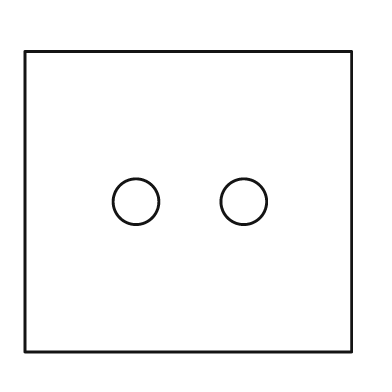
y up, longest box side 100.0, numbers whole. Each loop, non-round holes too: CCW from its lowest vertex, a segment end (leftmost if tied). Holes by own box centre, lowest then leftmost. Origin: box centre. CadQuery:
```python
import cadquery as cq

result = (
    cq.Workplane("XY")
    .moveTo(-50.0, -46.0)
    .lineTo(50.0, -46.0)
    .lineTo(50.0, 46.0)
    .lineTo(-50.0, 46.0)
    .close()
    .moveTo(-16.0, 0.0)
    .circle(7.0)
    .moveTo(17.0, 0.0)
    .circle(7.0)
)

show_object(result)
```